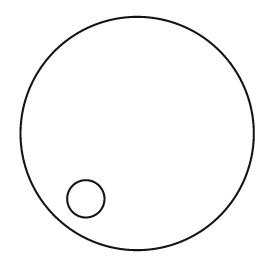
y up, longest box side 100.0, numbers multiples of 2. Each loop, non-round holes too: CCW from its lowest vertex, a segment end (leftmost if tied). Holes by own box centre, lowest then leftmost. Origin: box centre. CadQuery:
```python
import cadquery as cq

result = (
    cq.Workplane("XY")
    .moveTo(0.0, 0.0)
    .circle(50.0)
    .moveTo(-22.0, -28.0)
    .circle(8.0)
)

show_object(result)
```